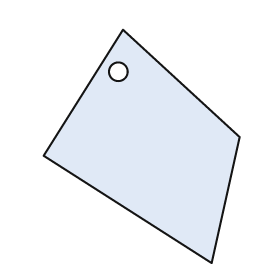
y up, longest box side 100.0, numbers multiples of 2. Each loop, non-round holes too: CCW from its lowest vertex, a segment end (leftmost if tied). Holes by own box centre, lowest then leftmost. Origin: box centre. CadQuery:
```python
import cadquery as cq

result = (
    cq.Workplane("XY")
    .moveTo(30.0, -50.0)
    .lineTo(42.0, 4.0)
    .lineTo(-8.0, 50.0)
    .lineTo(-42.0, -4.0)
    .close()
    .moveTo(-10.0, 32.0)
    .circle(4.0)
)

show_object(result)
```